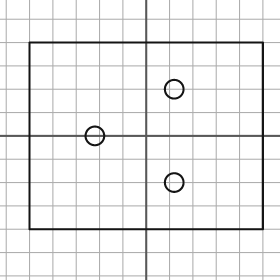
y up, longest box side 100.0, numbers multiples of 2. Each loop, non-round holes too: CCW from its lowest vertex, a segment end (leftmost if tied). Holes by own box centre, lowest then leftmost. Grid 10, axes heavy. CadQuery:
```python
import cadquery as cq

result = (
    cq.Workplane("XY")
    .moveTo(-50.0, -40.0)
    .lineTo(50.0, -40.0)
    .lineTo(50.0, 40.0)
    .lineTo(-50.0, 40.0)
    .close()
    .moveTo(12.0, -20.0)
    .circle(4.0)
    .moveTo(-22.0, 0.0)
    .circle(4.0)
    .moveTo(12.0, 20.0)
    .circle(4.0)
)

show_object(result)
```